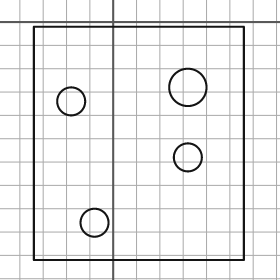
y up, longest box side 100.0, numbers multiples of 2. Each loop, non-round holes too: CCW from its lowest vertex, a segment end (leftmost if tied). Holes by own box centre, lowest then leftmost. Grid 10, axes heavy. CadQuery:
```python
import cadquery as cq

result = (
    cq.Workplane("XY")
    .moveTo(-34.0, -102.0)
    .lineTo(56.0, -102.0)
    .lineTo(56.0, -2.0)
    .lineTo(-34.0, -2.0)
    .close()
    .moveTo(-8.0, -86.0)
    .circle(6.0)
    .moveTo(32.0, -58.0)
    .circle(6.0)
    .moveTo(-18.0, -34.0)
    .circle(6.0)
    .moveTo(32.0, -28.0)
    .circle(8.0)
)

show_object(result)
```